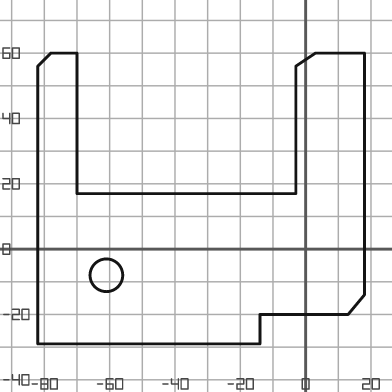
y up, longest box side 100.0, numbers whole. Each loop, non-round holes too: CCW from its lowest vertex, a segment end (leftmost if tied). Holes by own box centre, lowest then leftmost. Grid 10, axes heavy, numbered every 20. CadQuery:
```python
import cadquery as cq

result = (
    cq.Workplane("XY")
    .moveTo(-82.0, -29.0)
    .lineTo(-14.0, -29.0)
    .lineTo(-14.0, -20.0)
    .lineTo(13.0, -20.0)
    .lineTo(18.0, -14.0)
    .lineTo(18.0, 60.0)
    .lineTo(3.0, 60.0)
    .lineTo(-3.0, 56.0)
    .lineTo(-3.0, 17.0)
    .lineTo(-70.0, 17.0)
    .lineTo(-70.0, 60.0)
    .lineTo(-78.0, 60.0)
    .lineTo(-82.0, 56.0)
    .close()
    .moveTo(-61.0, -8.0)
    .circle(5.0)
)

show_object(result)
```